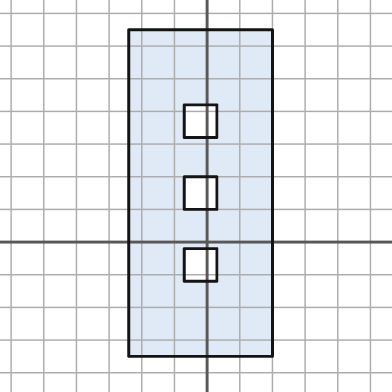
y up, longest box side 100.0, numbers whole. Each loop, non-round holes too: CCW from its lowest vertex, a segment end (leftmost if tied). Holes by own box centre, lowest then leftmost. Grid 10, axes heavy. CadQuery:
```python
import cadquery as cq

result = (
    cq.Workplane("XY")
    .moveTo(-24.0, -35.0)
    .lineTo(20.0, -35.0)
    .lineTo(20.0, 65.0)
    .lineTo(-24.0, 65.0)
    .close()
    .moveTo(-7.0, -12.0)
    .lineTo(3.0, -12.0)
    .lineTo(3.0, -2.0)
    .lineTo(-7.0, -2.0)
    .close()
    .moveTo(-7.0, 10.0)
    .lineTo(3.0, 10.0)
    .lineTo(3.0, 20.0)
    .lineTo(-7.0, 20.0)
    .close()
    .moveTo(-7.0, 32.0)
    .lineTo(3.0, 32.0)
    .lineTo(3.0, 42.0)
    .lineTo(-7.0, 42.0)
    .close()
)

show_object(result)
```